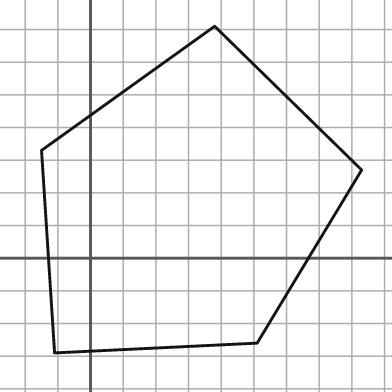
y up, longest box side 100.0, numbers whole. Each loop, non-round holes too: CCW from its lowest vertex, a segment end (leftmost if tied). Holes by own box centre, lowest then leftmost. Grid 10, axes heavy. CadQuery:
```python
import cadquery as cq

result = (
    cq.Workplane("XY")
    .moveTo(-11.0, -29.0)
    .lineTo(51.0, -26.0)
    .lineTo(83.0, 27.0)
    .lineTo(38.0, 71.0)
    .lineTo(-15.0, 33.0)
    .close()
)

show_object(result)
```